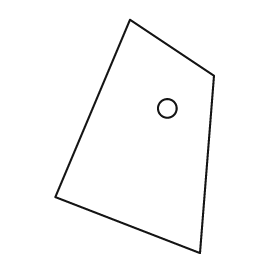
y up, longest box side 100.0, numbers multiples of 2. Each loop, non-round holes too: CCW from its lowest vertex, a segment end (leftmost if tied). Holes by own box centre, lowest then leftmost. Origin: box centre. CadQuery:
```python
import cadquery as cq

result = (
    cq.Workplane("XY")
    .moveTo(28.0, -50.0)
    .lineTo(34.0, 26.0)
    .lineTo(-2.0, 50.0)
    .lineTo(-34.0, -26.0)
    .close()
    .moveTo(14.0, 12.0)
    .circle(4.0)
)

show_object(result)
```